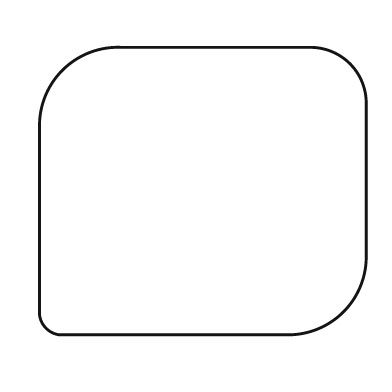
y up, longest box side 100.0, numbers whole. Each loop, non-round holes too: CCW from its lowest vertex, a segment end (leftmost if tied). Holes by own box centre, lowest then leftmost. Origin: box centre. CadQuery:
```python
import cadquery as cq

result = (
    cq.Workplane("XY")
    .moveTo(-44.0, -44.0)
    .lineTo(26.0, -44.0)
    .threePointArc((43.0, -37.0), (50.0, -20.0))
    .lineTo(50.0, 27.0)
    .threePointArc((45.0, 39.0), (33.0, 44.0))
    .lineTo(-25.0, 44.0)
    .threePointArc((-43.0, 37.0), (-50.0, 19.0))
    .lineTo(-50.0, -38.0)
    .threePointArc((-48.0, -42.0), (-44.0, -44.0))
    .close()
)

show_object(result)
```